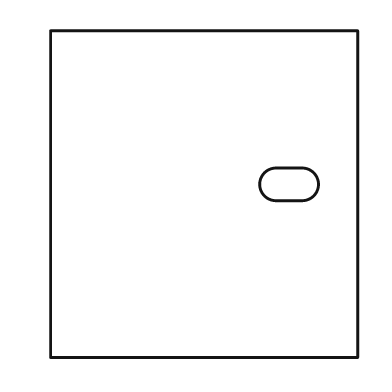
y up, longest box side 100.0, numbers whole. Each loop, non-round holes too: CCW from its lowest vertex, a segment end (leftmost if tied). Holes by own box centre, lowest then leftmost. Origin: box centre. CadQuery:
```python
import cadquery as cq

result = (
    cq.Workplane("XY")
    .moveTo(-47.0, -50.0)
    .lineTo(47.0, -50.0)
    .lineTo(47.0, 50.0)
    .lineTo(-47.0, 50.0)
    .close()
    .moveTo(22.0, -2.0)
    .lineTo(30.0, -2.0)
    .threePointArc((35.0, 3.0), (30.0, 8.0))
    .lineTo(22.0, 8.0)
    .threePointArc((17.0, 3.0), (22.0, -2.0))
    .close()
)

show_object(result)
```